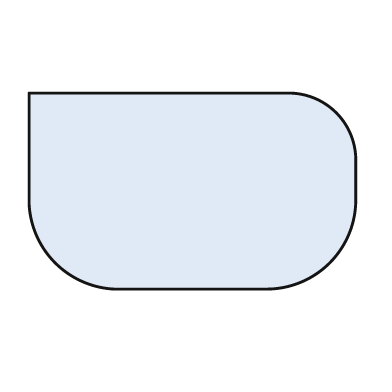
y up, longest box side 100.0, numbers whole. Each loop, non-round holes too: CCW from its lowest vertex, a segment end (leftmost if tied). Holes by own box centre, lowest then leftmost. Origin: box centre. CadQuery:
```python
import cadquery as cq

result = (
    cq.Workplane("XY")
    .moveTo(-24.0, -30.0)
    .lineTo(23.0, -30.0)
    .threePointArc((42.0, -22.0), (50.0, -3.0))
    .lineTo(50.0, 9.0)
    .threePointArc((44.0, 24.0), (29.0, 30.0))
    .lineTo(-50.0, 30.0)
    .lineTo(-50.0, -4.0)
    .threePointArc((-42.0, -22.0), (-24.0, -30.0))
    .close()
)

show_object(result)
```